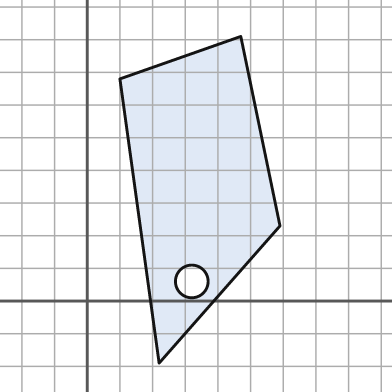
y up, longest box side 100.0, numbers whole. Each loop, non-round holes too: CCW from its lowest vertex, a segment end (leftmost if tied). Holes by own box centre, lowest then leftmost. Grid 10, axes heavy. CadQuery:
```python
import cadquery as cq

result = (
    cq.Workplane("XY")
    .moveTo(22.0, -19.0)
    .lineTo(59.0, 23.0)
    .lineTo(47.0, 81.0)
    .lineTo(10.0, 68.0)
    .close()
    .moveTo(32.0, 6.0)
    .circle(5.0)
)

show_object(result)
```